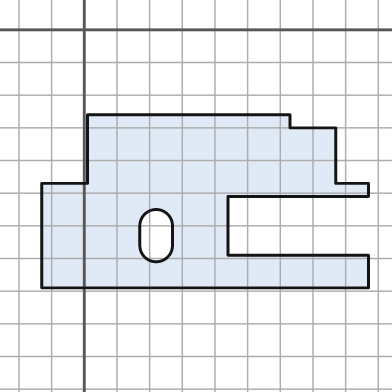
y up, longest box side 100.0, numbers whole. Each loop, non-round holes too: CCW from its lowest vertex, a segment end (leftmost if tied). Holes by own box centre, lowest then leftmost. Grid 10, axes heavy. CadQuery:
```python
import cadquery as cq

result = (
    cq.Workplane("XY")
    .moveTo(-13.0, -79.0)
    .lineTo(87.0, -79.0)
    .lineTo(87.0, -69.0)
    .lineTo(44.0, -69.0)
    .lineTo(44.0, -51.0)
    .lineTo(87.0, -51.0)
    .lineTo(87.0, -47.0)
    .lineTo(77.0, -47.0)
    .lineTo(77.0, -30.0)
    .lineTo(63.0, -30.0)
    .lineTo(63.0, -26.0)
    .lineTo(1.0, -26.0)
    .lineTo(1.0, -47.0)
    .lineTo(-13.0, -47.0)
    .close()
    .moveTo(17.0, -66.0)
    .threePointArc((22.0, -71.0), (27.0, -66.0))
    .lineTo(27.0, -60.0)
    .threePointArc((22.0, -55.0), (17.0, -60.0))
    .close()
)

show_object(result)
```